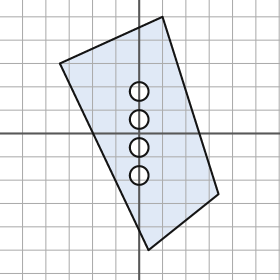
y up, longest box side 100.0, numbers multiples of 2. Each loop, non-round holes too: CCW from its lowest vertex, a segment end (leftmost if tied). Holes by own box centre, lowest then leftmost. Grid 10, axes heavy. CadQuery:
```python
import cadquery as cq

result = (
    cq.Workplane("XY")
    .moveTo(4.0, -50.0)
    .lineTo(34.0, -26.0)
    .lineTo(10.0, 50.0)
    .lineTo(-34.0, 30.0)
    .close()
    .moveTo(0.0, -18.0)
    .circle(4.0)
    .moveTo(0.0, -6.0)
    .circle(4.0)
    .moveTo(0.0, 6.0)
    .circle(4.0)
    .moveTo(0.0, 18.0)
    .circle(4.0)
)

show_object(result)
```